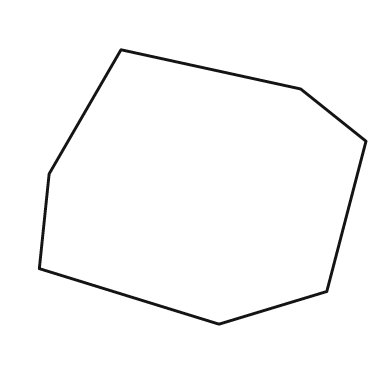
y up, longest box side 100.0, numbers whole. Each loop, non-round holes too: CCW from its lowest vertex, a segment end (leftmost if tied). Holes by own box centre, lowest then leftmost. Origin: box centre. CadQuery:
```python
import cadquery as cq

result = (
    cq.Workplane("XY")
    .moveTo(5.0, -42.0)
    .lineTo(38.0, -32.0)
    .lineTo(50.0, 14.0)
    .lineTo(30.0, 30.0)
    .lineTo(-25.0, 42.0)
    .lineTo(-47.0, 4.0)
    .lineTo(-50.0, -25.0)
    .close()
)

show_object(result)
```